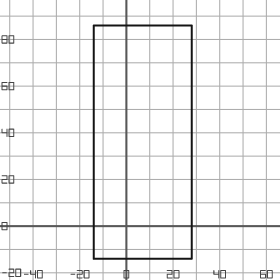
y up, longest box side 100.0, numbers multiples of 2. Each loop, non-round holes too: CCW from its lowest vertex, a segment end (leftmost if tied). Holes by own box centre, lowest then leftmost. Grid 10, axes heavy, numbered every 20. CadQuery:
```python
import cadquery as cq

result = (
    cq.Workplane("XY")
    .moveTo(-14.0, -14.0)
    .lineTo(28.0, -14.0)
    .lineTo(28.0, 86.0)
    .lineTo(-14.0, 86.0)
    .close()
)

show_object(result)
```